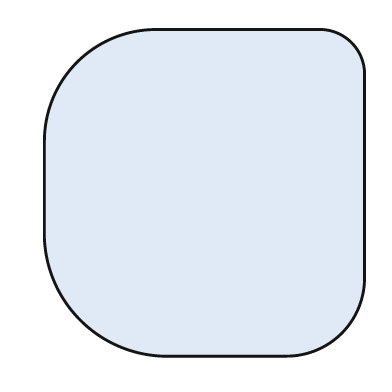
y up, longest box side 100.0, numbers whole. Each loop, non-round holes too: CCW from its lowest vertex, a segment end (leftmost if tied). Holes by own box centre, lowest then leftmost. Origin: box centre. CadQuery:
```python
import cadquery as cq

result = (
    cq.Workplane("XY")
    .moveTo(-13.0, -50.0)
    .lineTo(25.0, -50.0)
    .threePointArc((42.0, -43.0), (49.0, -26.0))
    .lineTo(49.0, 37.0)
    .threePointArc((45.0, 46.0), (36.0, 50.0))
    .lineTo(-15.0, 50.0)
    .threePointArc((-39.0, 40.0), (-49.0, 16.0))
    .lineTo(-49.0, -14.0)
    .threePointArc((-38.0, -39.0), (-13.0, -50.0))
    .close()
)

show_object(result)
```